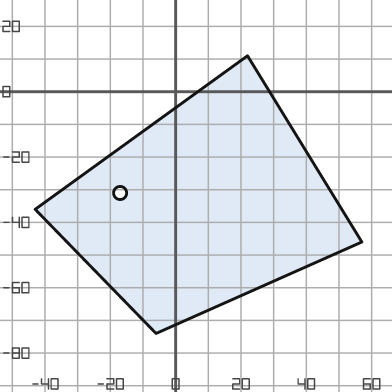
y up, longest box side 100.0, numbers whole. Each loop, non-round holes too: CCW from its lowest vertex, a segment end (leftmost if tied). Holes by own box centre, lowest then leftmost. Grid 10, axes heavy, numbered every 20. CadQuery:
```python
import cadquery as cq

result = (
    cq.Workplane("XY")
    .moveTo(-6.0, -74.0)
    .lineTo(57.0, -46.0)
    .lineTo(22.0, 11.0)
    .lineTo(-43.0, -36.0)
    .close()
    .moveTo(-17.0, -31.0)
    .circle(2.0)
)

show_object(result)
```